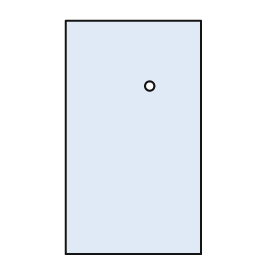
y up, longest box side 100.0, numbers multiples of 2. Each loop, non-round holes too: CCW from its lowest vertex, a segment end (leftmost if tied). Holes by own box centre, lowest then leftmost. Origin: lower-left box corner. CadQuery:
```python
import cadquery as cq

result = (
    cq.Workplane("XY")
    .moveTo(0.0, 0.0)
    .lineTo(58.0, 0.0)
    .lineTo(58.0, 100.0)
    .lineTo(0.0, 100.0)
    .close()
    .moveTo(36.0, 72.0)
    .circle(2.0)
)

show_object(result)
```